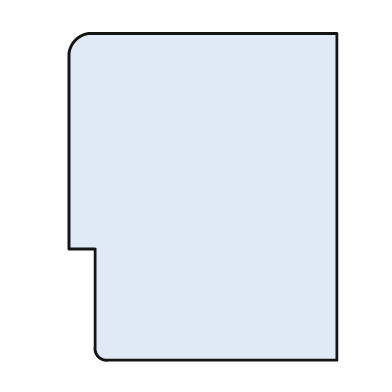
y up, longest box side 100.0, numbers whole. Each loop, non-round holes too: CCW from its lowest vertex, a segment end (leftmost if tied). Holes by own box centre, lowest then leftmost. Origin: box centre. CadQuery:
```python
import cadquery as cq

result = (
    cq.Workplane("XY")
    .moveTo(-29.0, -50.0)
    .lineTo(41.0, -50.0)
    .lineTo(41.0, 50.0)
    .lineTo(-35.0, 50.0)
    .threePointArc((-39.0, 48.0), (-41.0, 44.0))
    .lineTo(-41.0, -16.0)
    .lineTo(-33.0, -16.0)
    .lineTo(-33.0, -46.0)
    .threePointArc((-32.0, -49.0), (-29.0, -50.0))
    .close()
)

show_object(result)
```